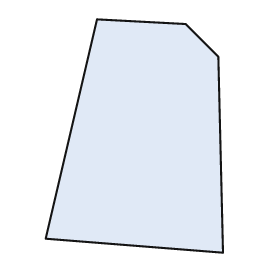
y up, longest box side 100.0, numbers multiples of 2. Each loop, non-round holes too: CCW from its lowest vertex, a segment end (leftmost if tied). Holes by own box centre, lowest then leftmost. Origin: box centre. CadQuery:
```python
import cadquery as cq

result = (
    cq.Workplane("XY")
    .moveTo(38.0, -50.0)
    .lineTo(36.0, 34.0)
    .lineTo(22.0, 48.0)
    .lineTo(-16.0, 50.0)
    .lineTo(-38.0, -44.0)
    .close()
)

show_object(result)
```